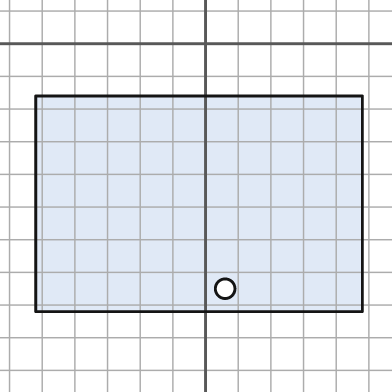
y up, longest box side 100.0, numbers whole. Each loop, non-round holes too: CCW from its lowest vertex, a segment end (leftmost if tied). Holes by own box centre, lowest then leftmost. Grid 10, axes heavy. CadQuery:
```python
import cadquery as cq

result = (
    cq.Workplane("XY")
    .moveTo(-52.0, -82.0)
    .lineTo(48.0, -82.0)
    .lineTo(48.0, -16.0)
    .lineTo(-52.0, -16.0)
    .close()
    .moveTo(6.0, -75.0)
    .circle(3.0)
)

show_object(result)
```